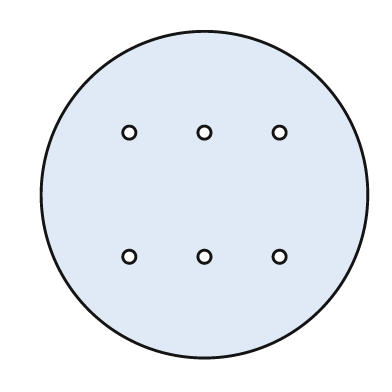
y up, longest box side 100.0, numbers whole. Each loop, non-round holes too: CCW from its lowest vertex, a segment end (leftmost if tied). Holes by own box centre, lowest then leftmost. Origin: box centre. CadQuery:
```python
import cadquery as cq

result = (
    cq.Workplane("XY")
    .moveTo(0.0, 0.0)
    .circle(50.0)
    .moveTo(-23.0, -19.0)
    .circle(2.0)
    .moveTo(0.0, -19.0)
    .circle(2.0)
    .moveTo(23.0, -19.0)
    .circle(2.0)
    .moveTo(-23.0, 19.0)
    .circle(2.0)
    .moveTo(0.0, 19.0)
    .circle(2.0)
    .moveTo(23.0, 19.0)
    .circle(2.0)
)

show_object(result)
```